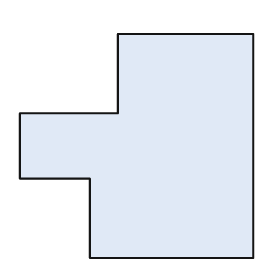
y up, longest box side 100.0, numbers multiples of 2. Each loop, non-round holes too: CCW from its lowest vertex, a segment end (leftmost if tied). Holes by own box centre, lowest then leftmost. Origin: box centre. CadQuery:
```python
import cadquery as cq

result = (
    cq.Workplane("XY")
    .moveTo(-20.0, -48.0)
    .lineTo(50.0, -48.0)
    .lineTo(50.0, 48.0)
    .lineTo(-8.0, 48.0)
    .lineTo(-8.0, 14.0)
    .lineTo(-50.0, 14.0)
    .lineTo(-50.0, -14.0)
    .lineTo(-20.0, -14.0)
    .close()
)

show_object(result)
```